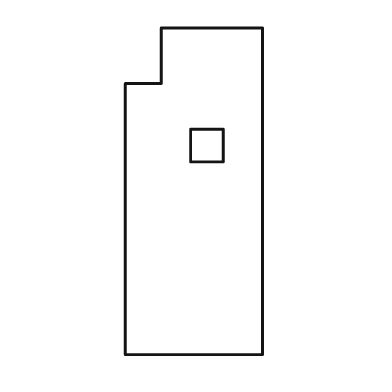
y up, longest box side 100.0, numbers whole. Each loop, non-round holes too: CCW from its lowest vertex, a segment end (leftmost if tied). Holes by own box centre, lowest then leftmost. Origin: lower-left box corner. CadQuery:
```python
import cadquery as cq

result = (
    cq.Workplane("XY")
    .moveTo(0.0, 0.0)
    .lineTo(42.0, 0.0)
    .lineTo(42.0, 100.0)
    .lineTo(11.0, 100.0)
    .lineTo(11.0, 83.0)
    .lineTo(0.0, 83.0)
    .close()
    .moveTo(20.0, 59.0)
    .lineTo(30.0, 59.0)
    .lineTo(30.0, 69.0)
    .lineTo(20.0, 69.0)
    .close()
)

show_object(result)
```